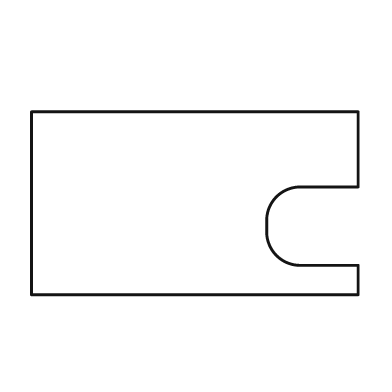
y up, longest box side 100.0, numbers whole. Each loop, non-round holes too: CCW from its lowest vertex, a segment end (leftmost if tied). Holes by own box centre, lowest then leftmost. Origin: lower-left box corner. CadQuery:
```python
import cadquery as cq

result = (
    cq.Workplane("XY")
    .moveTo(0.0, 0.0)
    .lineTo(100.0, 0.0)
    .lineTo(100.0, 9.0)
    .lineTo(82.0, 9.0)
    .threePointArc((75.0, 12.0), (72.0, 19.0))
    .lineTo(72.0, 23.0)
    .threePointArc((75.0, 30.0), (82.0, 33.0))
    .lineTo(100.0, 33.0)
    .lineTo(100.0, 56.0)
    .lineTo(0.0, 56.0)
    .close()
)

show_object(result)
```